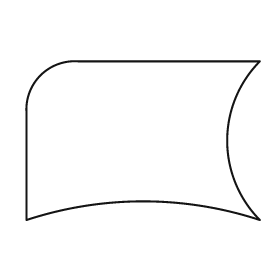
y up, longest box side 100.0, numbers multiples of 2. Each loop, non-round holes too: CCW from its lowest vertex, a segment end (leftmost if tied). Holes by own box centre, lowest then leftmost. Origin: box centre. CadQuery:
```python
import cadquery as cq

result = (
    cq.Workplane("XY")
    .moveTo(-50.0, -34.0)
    .threePointArc((0.0, -26.0), (50.0, -34.0))
    .threePointArc((36.0, 0.0), (50.0, 34.0))
    .lineTo(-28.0, 34.0)
    .threePointArc((-44.0, 28.0), (-50.0, 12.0))
    .close()
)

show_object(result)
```